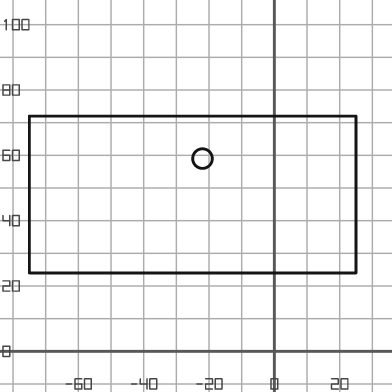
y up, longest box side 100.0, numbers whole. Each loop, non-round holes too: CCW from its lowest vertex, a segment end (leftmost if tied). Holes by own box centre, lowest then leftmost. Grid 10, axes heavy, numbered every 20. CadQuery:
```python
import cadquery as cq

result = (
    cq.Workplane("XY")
    .moveTo(-75.0, 24.0)
    .lineTo(25.0, 24.0)
    .lineTo(25.0, 72.0)
    .lineTo(-75.0, 72.0)
    .close()
    .moveTo(-22.0, 59.0)
    .circle(3.0)
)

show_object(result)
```